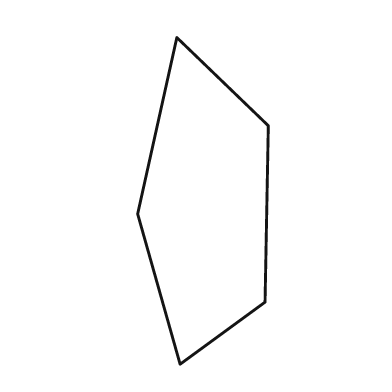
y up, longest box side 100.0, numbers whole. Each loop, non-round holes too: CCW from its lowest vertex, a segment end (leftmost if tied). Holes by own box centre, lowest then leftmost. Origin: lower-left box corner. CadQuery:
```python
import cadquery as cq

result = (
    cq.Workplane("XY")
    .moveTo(13.0, 0.0)
    .lineTo(39.0, 19.0)
    .lineTo(40.0, 73.0)
    .lineTo(12.0, 100.0)
    .lineTo(0.0, 46.0)
    .close()
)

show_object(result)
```